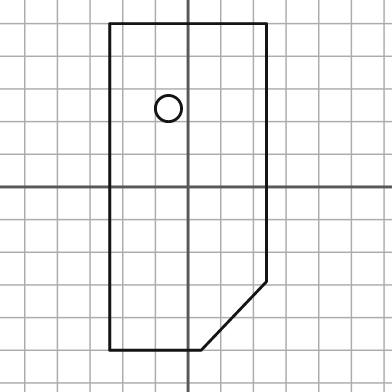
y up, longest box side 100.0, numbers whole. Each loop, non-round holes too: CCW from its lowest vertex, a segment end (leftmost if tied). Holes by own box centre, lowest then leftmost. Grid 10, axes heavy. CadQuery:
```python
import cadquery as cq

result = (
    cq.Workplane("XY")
    .moveTo(-24.0, -50.0)
    .lineTo(4.0, -50.0)
    .lineTo(24.0, -29.0)
    .lineTo(24.0, 50.0)
    .lineTo(-24.0, 50.0)
    .close()
    .moveTo(-6.0, 24.0)
    .circle(4.0)
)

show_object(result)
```